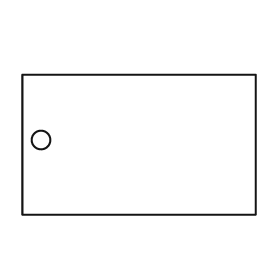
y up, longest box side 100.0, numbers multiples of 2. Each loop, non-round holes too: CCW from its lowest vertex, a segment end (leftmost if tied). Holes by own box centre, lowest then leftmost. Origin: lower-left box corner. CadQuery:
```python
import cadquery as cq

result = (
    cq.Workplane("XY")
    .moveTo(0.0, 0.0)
    .lineTo(100.0, 0.0)
    .lineTo(100.0, 60.0)
    .lineTo(0.0, 60.0)
    .close()
    .moveTo(8.0, 32.0)
    .circle(4.0)
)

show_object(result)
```